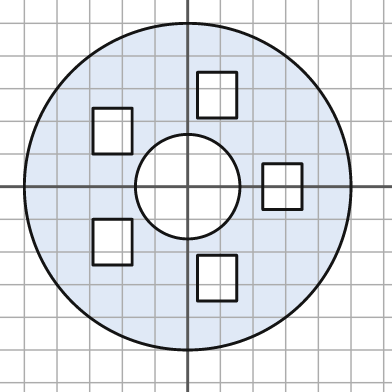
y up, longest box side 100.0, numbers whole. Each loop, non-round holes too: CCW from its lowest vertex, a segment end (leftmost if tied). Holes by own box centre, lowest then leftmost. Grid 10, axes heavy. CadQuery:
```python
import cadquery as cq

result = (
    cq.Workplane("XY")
    .moveTo(0.0, 0.0)
    .circle(50.0)
    .moveTo(3.0, -35.0)
    .lineTo(15.0, -35.0)
    .lineTo(15.0, -21.0)
    .lineTo(3.0, -21.0)
    .close()
    .moveTo(-29.0, -24.0)
    .lineTo(-17.0, -24.0)
    .lineTo(-17.0, -10.0)
    .lineTo(-29.0, -10.0)
    .close()
    .moveTo(0.0, 0.0)
    .circle(16.0)
    .moveTo(23.0, -7.0)
    .lineTo(35.0, -7.0)
    .lineTo(35.0, 7.0)
    .lineTo(23.0, 7.0)
    .close()
    .moveTo(-29.0, 10.0)
    .lineTo(-17.0, 10.0)
    .lineTo(-17.0, 24.0)
    .lineTo(-29.0, 24.0)
    .close()
    .moveTo(3.0, 21.0)
    .lineTo(15.0, 21.0)
    .lineTo(15.0, 35.0)
    .lineTo(3.0, 35.0)
    .close()
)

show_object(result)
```